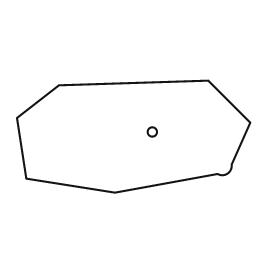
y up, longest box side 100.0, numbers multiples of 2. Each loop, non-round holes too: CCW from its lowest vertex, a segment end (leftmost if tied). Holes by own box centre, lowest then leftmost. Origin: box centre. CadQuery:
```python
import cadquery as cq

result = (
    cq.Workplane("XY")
    .moveTo(-8.0, -24.0)
    .lineTo(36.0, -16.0)
    .threePointArc((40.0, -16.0), (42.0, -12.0))
    .lineTo(50.0, 6.0)
    .lineTo(32.0, 24.0)
    .lineTo(-32.0, 22.0)
    .lineTo(-50.0, 8.0)
    .lineTo(-46.0, -18.0)
    .close()
    .moveTo(8.0, 2.0)
    .circle(2.0)
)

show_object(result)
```